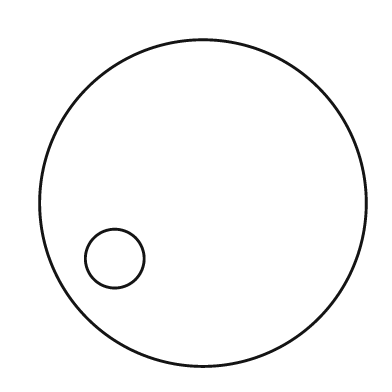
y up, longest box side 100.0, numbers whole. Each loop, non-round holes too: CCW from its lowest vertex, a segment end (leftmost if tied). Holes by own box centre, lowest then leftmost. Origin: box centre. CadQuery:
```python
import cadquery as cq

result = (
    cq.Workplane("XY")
    .moveTo(0.0, 0.0)
    .circle(50.0)
    .moveTo(-27.0, -17.0)
    .circle(9.0)
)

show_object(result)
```